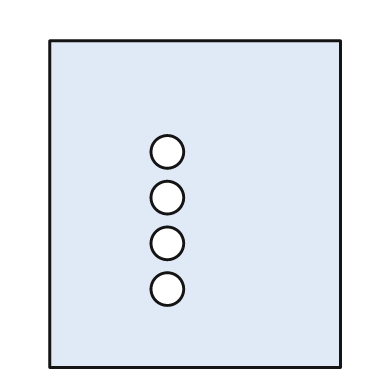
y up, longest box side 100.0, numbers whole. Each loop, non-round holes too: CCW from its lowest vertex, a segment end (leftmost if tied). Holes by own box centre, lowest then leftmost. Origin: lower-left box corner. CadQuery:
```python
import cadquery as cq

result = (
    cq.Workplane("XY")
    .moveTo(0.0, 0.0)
    .lineTo(89.0, 0.0)
    .lineTo(89.0, 100.0)
    .lineTo(0.0, 100.0)
    .close()
    .moveTo(36.0, 24.0)
    .circle(5.0)
    .moveTo(36.0, 38.0)
    .circle(5.0)
    .moveTo(36.0, 52.0)
    .circle(5.0)
    .moveTo(36.0, 66.0)
    .circle(5.0)
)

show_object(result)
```